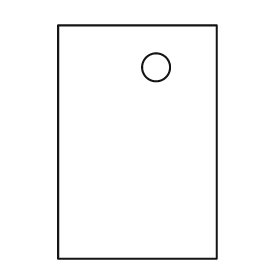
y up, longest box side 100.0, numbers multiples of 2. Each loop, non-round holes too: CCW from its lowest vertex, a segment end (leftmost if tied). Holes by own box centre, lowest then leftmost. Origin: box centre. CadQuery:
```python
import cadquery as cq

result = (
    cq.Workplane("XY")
    .moveTo(-34.0, -50.0)
    .lineTo(34.0, -50.0)
    .lineTo(34.0, 50.0)
    .lineTo(-34.0, 50.0)
    .close()
    .moveTo(8.0, 32.0)
    .circle(6.0)
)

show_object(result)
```